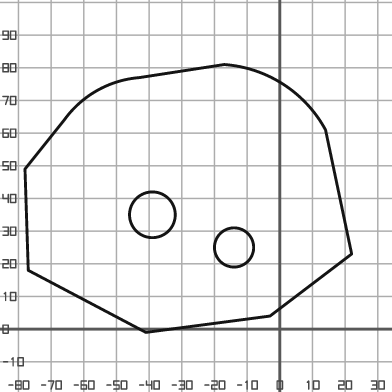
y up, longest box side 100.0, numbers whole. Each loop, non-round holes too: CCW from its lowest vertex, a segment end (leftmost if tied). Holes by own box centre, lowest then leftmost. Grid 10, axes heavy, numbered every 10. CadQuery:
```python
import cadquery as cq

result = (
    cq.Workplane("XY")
    .moveTo(-41.0, -1.0)
    .lineTo(-3.0, 4.0)
    .lineTo(22.0, 23.0)
    .lineTo(14.0, 61.0)
    .threePointArc((1.0, 75.0), (-17.0, 81.0))
    .lineTo(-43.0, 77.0)
    .threePointArc((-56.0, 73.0), (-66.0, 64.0))
    .lineTo(-78.0, 49.0)
    .lineTo(-77.0, 18.0)
    .close()
    .moveTo(-14.0, 25.0)
    .circle(6.0)
    .moveTo(-39.0, 35.0)
    .circle(7.0)
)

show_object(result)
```